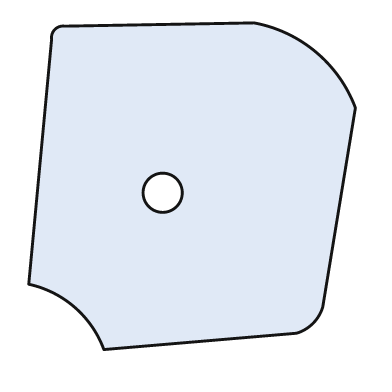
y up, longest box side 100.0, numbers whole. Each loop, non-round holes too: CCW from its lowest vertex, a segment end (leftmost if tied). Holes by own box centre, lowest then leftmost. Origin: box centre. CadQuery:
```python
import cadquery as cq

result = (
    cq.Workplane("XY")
    .moveTo(-27.0, -50.0)
    .lineTo(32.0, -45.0)
    .threePointArc((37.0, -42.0), (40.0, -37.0))
    .lineTo(50.0, 24.0)
    .threePointArc((38.0, 41.0), (19.0, 50.0))
    .lineTo(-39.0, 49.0)
    .threePointArc((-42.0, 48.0), (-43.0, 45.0))
    .lineTo(-50.0, -30.0)
    .threePointArc((-36.0, -37.0), (-27.0, -50.0))
    .close()
    .moveTo(-9.0, -2.0)
    .circle(6.0)
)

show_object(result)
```